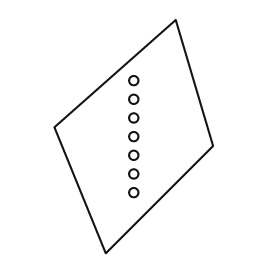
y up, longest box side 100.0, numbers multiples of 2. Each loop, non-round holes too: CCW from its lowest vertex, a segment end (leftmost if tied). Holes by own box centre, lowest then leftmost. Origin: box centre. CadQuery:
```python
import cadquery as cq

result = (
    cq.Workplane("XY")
    .moveTo(-12.0, -50.0)
    .lineTo(34.0, -4.0)
    .lineTo(18.0, 50.0)
    .lineTo(-34.0, 4.0)
    .close()
    .moveTo(0.0, -24.0)
    .circle(2.0)
    .moveTo(0.0, -16.0)
    .circle(2.0)
    .moveTo(0.0, -8.0)
    .circle(2.0)
    .moveTo(0.0, 0.0)
    .circle(2.0)
    .moveTo(0.0, 8.0)
    .circle(2.0)
    .moveTo(0.0, 16.0)
    .circle(2.0)
    .moveTo(0.0, 24.0)
    .circle(2.0)
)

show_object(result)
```